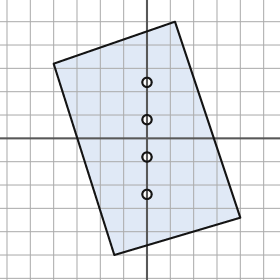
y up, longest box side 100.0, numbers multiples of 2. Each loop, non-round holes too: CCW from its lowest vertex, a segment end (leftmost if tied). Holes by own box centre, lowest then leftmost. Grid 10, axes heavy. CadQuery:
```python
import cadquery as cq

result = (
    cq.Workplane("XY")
    .moveTo(-14.0, -50.0)
    .lineTo(40.0, -34.0)
    .lineTo(12.0, 50.0)
    .lineTo(-40.0, 32.0)
    .close()
    .moveTo(0.0, -24.0)
    .circle(2.0)
    .moveTo(0.0, -8.0)
    .circle(2.0)
    .moveTo(0.0, 8.0)
    .circle(2.0)
    .moveTo(0.0, 24.0)
    .circle(2.0)
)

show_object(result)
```